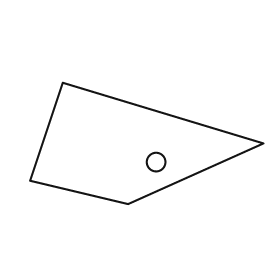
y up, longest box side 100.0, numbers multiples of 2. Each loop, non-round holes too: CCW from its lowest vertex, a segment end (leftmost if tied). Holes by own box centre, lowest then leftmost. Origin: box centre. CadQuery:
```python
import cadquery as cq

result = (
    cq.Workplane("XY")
    .moveTo(-8.0, -26.0)
    .lineTo(50.0, 0.0)
    .lineTo(-36.0, 26.0)
    .lineTo(-50.0, -16.0)
    .close()
    .moveTo(4.0, -8.0)
    .circle(4.0)
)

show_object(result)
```